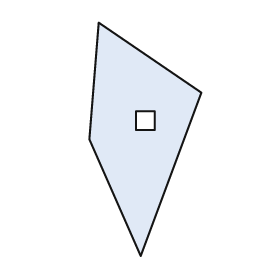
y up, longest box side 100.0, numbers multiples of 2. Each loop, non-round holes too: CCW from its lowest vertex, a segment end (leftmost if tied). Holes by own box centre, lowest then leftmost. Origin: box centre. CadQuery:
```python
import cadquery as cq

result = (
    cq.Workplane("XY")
    .moveTo(-2.0, -50.0)
    .lineTo(24.0, 20.0)
    .lineTo(-20.0, 50.0)
    .lineTo(-24.0, 0.0)
    .close()
    .moveTo(-4.0, 4.0)
    .lineTo(4.0, 4.0)
    .lineTo(4.0, 12.0)
    .lineTo(-4.0, 12.0)
    .close()
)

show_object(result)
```